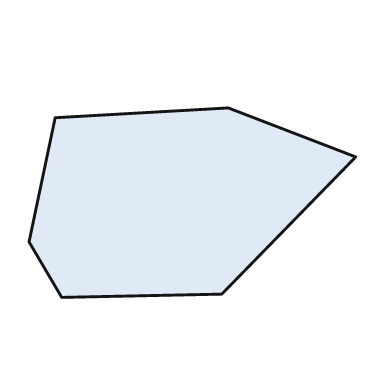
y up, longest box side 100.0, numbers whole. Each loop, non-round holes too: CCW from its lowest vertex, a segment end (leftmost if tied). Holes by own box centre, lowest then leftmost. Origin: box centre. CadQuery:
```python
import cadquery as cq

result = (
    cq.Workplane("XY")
    .moveTo(-40.0, -29.0)
    .lineTo(9.0, -28.0)
    .lineTo(50.0, 14.0)
    .lineTo(11.0, 29.0)
    .lineTo(-42.0, 26.0)
    .lineTo(-50.0, -12.0)
    .close()
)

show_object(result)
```